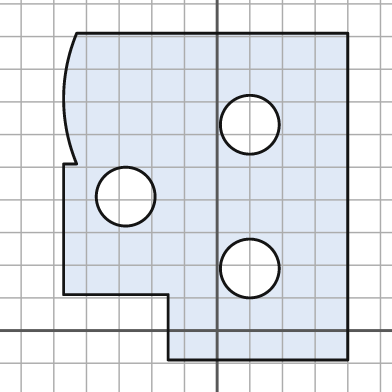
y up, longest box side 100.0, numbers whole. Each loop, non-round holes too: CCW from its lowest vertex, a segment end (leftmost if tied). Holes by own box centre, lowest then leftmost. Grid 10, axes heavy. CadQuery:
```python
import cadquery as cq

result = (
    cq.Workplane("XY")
    .moveTo(-15.0, -9.0)
    .lineTo(40.0, -9.0)
    .lineTo(40.0, 91.0)
    .lineTo(-43.0, 91.0)
    .threePointArc((-47.0, 71.0), (-43.0, 51.0))
    .lineTo(-47.0, 51.0)
    .lineTo(-47.0, 11.0)
    .lineTo(-15.0, 11.0)
    .close()
    .moveTo(10.0, 19.0)
    .circle(9.0)
    .moveTo(-28.0, 41.0)
    .circle(9.0)
    .moveTo(10.0, 63.0)
    .circle(9.0)
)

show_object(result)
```